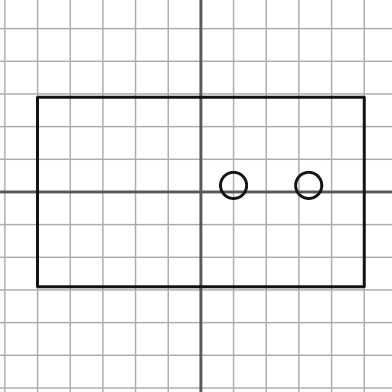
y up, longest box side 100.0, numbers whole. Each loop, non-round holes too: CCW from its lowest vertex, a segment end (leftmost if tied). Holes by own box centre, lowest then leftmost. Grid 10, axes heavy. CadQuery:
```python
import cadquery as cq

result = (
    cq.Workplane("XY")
    .moveTo(-50.0, -29.0)
    .lineTo(50.0, -29.0)
    .lineTo(50.0, 29.0)
    .lineTo(-50.0, 29.0)
    .close()
    .moveTo(10.0, 2.0)
    .circle(4.0)
    .moveTo(33.0, 2.0)
    .circle(4.0)
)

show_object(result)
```